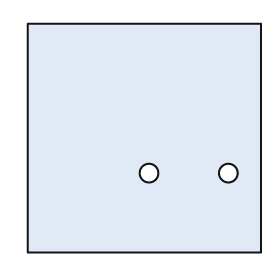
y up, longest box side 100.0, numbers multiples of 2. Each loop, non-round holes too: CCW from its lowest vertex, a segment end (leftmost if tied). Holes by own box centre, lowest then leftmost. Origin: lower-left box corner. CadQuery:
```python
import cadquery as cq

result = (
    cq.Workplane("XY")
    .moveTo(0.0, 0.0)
    .lineTo(100.0, 0.0)
    .lineTo(100.0, 98.0)
    .lineTo(0.0, 98.0)
    .close()
    .moveTo(52.0, 34.0)
    .circle(4.0)
    .moveTo(86.0, 34.0)
    .circle(4.0)
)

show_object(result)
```